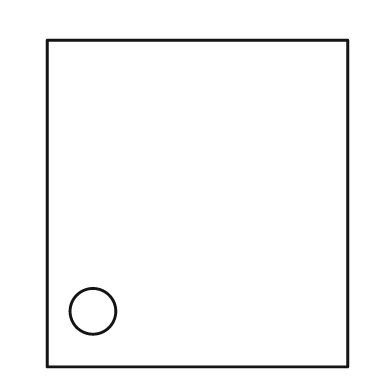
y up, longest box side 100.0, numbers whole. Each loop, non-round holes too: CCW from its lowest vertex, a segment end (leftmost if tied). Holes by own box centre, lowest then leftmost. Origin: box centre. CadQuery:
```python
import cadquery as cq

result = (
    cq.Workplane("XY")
    .moveTo(-46.0, -50.0)
    .lineTo(46.0, -50.0)
    .lineTo(46.0, 50.0)
    .lineTo(-46.0, 50.0)
    .close()
    .moveTo(-32.0, -33.0)
    .circle(7.0)
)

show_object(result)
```